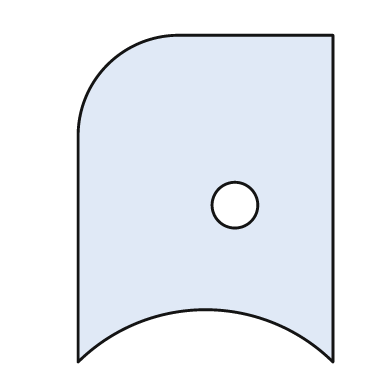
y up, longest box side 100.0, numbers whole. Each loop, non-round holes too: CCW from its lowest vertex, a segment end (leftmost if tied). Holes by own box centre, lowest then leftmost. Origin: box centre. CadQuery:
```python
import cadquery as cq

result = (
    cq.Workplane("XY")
    .moveTo(-39.0, -50.0)
    .threePointArc((0.0, -34.0), (39.0, -50.0))
    .lineTo(39.0, 50.0)
    .lineTo(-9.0, 50.0)
    .threePointArc((-30.0, 41.0), (-39.0, 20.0))
    .close()
    .moveTo(9.0, -2.0)
    .circle(7.0)
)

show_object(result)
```